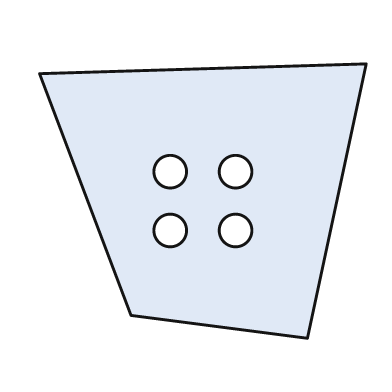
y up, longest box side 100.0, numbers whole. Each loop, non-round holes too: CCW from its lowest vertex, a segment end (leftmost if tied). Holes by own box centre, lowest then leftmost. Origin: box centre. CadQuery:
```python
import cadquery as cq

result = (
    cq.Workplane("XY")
    .moveTo(32.0, -42.0)
    .lineTo(50.0, 42.0)
    .lineTo(-50.0, 39.0)
    .lineTo(-22.0, -35.0)
    .close()
    .moveTo(-10.0, -9.0)
    .circle(5.0)
    .moveTo(10.0, -9.0)
    .circle(5.0)
    .moveTo(-10.0, 9.0)
    .circle(5.0)
    .moveTo(10.0, 9.0)
    .circle(5.0)
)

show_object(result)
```